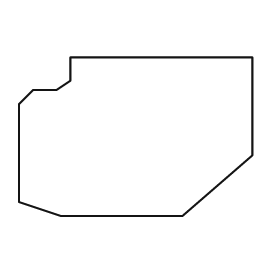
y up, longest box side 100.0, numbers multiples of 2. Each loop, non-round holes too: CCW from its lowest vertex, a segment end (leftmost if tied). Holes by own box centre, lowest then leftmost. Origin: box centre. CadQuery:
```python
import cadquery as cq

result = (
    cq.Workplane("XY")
    .moveTo(-32.0, -34.0)
    .lineTo(20.0, -34.0)
    .lineTo(50.0, -8.0)
    .lineTo(50.0, 34.0)
    .lineTo(-28.0, 34.0)
    .lineTo(-28.0, 24.0)
    .lineTo(-34.0, 20.0)
    .lineTo(-44.0, 20.0)
    .lineTo(-50.0, 14.0)
    .lineTo(-50.0, -28.0)
    .close()
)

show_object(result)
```